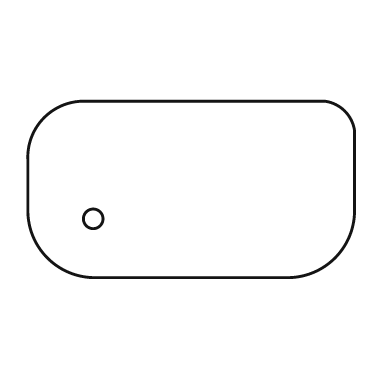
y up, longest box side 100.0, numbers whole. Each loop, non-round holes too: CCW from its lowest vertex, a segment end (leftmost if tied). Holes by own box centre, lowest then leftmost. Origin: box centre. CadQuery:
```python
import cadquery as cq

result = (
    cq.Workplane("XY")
    .moveTo(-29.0, -27.0)
    .lineTo(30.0, -27.0)
    .threePointArc((44.0, -21.0), (50.0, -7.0))
    .lineTo(50.0, 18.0)
    .threePointArc((47.0, 24.0), (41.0, 27.0))
    .lineTo(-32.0, 27.0)
    .threePointArc((-45.0, 22.0), (-50.0, 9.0))
    .lineTo(-50.0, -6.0)
    .threePointArc((-44.0, -21.0), (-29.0, -27.0))
    .close()
    .moveTo(-30.0, -9.0)
    .circle(3.0)
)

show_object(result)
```